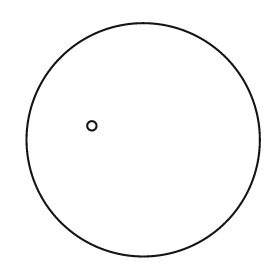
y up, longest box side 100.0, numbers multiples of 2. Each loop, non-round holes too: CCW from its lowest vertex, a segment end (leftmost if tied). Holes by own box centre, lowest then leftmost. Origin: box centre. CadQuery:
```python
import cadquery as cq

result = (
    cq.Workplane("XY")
    .moveTo(0.0, 0.0)
    .circle(50.0)
    .moveTo(-22.0, 6.0)
    .circle(2.0)
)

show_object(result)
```